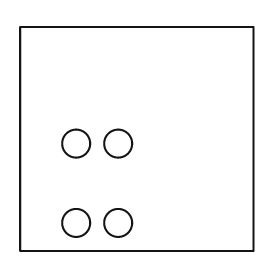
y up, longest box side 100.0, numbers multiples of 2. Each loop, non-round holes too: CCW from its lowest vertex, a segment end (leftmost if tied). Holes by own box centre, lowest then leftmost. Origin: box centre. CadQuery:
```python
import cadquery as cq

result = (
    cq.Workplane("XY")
    .moveTo(-50.0, -48.0)
    .lineTo(50.0, -48.0)
    .lineTo(50.0, 48.0)
    .lineTo(-50.0, 48.0)
    .close()
    .moveTo(-26.0, -36.0)
    .circle(6.0)
    .moveTo(-8.0, -36.0)
    .circle(6.0)
    .moveTo(-26.0, -2.0)
    .circle(6.0)
    .moveTo(-8.0, -2.0)
    .circle(6.0)
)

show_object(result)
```